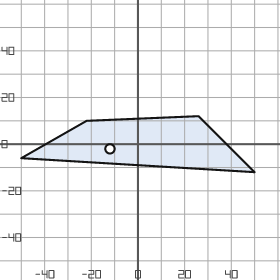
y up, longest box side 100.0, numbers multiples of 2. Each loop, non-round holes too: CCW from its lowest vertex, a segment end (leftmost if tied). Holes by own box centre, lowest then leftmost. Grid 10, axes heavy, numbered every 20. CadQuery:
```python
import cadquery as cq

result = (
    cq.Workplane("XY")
    .moveTo(50.0, -12.0)
    .lineTo(26.0, 12.0)
    .lineTo(-22.0, 10.0)
    .lineTo(-50.0, -6.0)
    .close()
    .moveTo(-12.0, -2.0)
    .circle(2.0)
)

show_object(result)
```